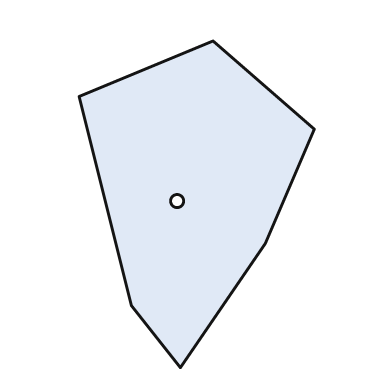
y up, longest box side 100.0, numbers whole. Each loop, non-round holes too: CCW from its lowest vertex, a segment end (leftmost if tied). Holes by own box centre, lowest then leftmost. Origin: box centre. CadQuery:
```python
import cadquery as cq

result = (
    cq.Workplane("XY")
    .moveTo(-5.0, -50.0)
    .lineTo(21.0, -12.0)
    .lineTo(36.0, 23.0)
    .lineTo(5.0, 50.0)
    .lineTo(-36.0, 33.0)
    .lineTo(-20.0, -31.0)
    .close()
    .moveTo(-6.0, 1.0)
    .circle(2.0)
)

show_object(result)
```